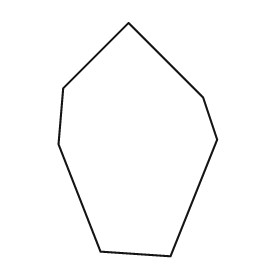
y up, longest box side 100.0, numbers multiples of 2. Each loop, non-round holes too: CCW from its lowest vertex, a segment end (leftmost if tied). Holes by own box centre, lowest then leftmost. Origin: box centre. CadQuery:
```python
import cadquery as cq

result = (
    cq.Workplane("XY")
    .moveTo(14.0, -50.0)
    .lineTo(34.0, 0.0)
    .lineTo(28.0, 18.0)
    .lineTo(-4.0, 50.0)
    .lineTo(-32.0, 22.0)
    .lineTo(-34.0, -2.0)
    .lineTo(-16.0, -48.0)
    .close()
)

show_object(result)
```